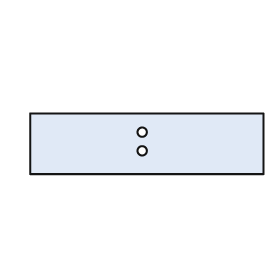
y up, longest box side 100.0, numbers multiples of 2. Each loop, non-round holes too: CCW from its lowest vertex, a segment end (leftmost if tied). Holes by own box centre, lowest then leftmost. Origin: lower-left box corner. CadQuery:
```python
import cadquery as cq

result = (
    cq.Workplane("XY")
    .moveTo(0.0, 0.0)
    .lineTo(100.0, 0.0)
    .lineTo(100.0, 26.0)
    .lineTo(0.0, 26.0)
    .close()
    .moveTo(48.0, 10.0)
    .circle(2.0)
    .moveTo(48.0, 18.0)
    .circle(2.0)
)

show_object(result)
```